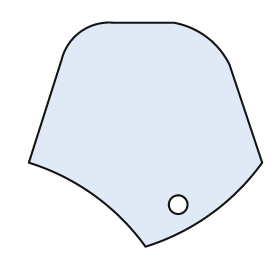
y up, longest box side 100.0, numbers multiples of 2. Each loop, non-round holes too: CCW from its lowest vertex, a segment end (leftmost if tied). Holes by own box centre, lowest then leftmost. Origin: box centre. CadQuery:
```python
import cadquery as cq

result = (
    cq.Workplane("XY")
    .moveTo(0.0, -48.0)
    .threePointArc((28.0, -34.0), (50.0, -12.0))
    .lineTo(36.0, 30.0)
    .threePointArc((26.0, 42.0), (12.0, 48.0))
    .lineTo(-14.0, 48.0)
    .threePointArc((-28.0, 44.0), (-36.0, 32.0))
    .lineTo(-50.0, -12.0)
    .threePointArc((-22.0, -26.0), (0.0, -48.0))
    .close()
    .moveTo(14.0, -30.0)
    .circle(4.0)
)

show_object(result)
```